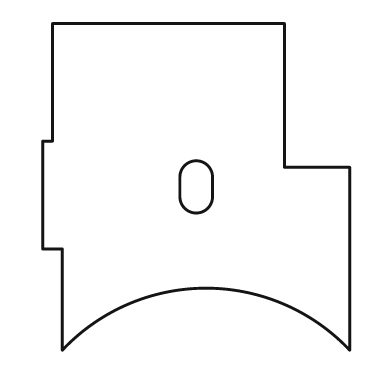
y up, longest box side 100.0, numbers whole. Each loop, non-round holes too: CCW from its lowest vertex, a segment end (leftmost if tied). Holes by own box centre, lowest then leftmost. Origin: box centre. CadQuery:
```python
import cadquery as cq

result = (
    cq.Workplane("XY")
    .moveTo(-41.0, -50.0)
    .threePointArc((3.0, -31.0), (47.0, -50.0))
    .lineTo(47.0, 6.0)
    .lineTo(27.0, 6.0)
    .lineTo(27.0, 50.0)
    .lineTo(-44.0, 50.0)
    .lineTo(-44.0, 14.0)
    .lineTo(-47.0, 14.0)
    .lineTo(-47.0, -19.0)
    .lineTo(-41.0, -19.0)
    .close()
    .moveTo(-5.0, -3.0)
    .threePointArc((0.0, -8.0), (5.0, -3.0))
    .lineTo(5.0, 3.0)
    .threePointArc((0.0, 8.0), (-5.0, 3.0))
    .close()
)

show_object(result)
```